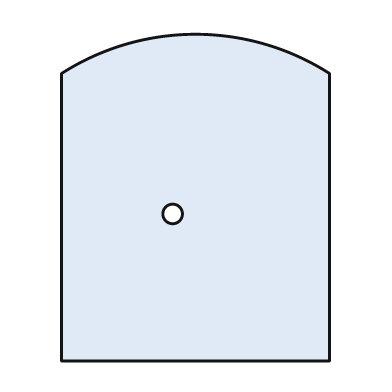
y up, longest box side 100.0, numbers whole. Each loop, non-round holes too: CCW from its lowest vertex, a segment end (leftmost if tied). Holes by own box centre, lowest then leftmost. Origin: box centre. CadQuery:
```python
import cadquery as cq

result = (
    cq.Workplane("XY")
    .moveTo(-41.0, -50.0)
    .lineTo(41.0, -50.0)
    .lineTo(41.0, 38.0)
    .threePointArc((0.0, 50.0), (-41.0, 38.0))
    .close()
    .moveTo(-7.0, -5.0)
    .circle(3.0)
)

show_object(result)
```